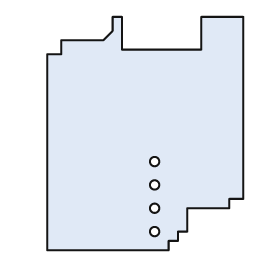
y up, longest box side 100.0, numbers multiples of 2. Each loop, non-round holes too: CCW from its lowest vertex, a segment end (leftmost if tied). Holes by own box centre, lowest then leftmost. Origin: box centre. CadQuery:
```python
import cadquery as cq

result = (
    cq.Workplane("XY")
    .moveTo(-42.0, -50.0)
    .lineTo(10.0, -50.0)
    .lineTo(10.0, -46.0)
    .lineTo(14.0, -46.0)
    .lineTo(14.0, -42.0)
    .lineTo(18.0, -42.0)
    .lineTo(18.0, -32.0)
    .lineTo(36.0, -32.0)
    .lineTo(36.0, -28.0)
    .lineTo(42.0, -28.0)
    .lineTo(42.0, 50.0)
    .lineTo(24.0, 50.0)
    .lineTo(24.0, 36.0)
    .lineTo(-10.0, 36.0)
    .lineTo(-10.0, 50.0)
    .lineTo(-14.0, 50.0)
    .lineTo(-14.0, 44.0)
    .lineTo(-18.0, 40.0)
    .lineTo(-36.0, 40.0)
    .lineTo(-36.0, 34.0)
    .lineTo(-42.0, 34.0)
    .close()
    .moveTo(4.0, -42.0)
    .circle(2.0)
    .moveTo(4.0, -32.0)
    .circle(2.0)
    .moveTo(4.0, -22.0)
    .circle(2.0)
    .moveTo(4.0, -12.0)
    .circle(2.0)
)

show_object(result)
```